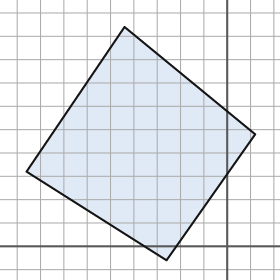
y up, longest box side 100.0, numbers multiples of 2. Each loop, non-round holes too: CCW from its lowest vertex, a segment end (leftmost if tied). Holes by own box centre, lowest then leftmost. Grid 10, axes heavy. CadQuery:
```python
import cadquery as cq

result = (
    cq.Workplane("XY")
    .moveTo(-26.0, -6.0)
    .lineTo(12.0, 48.0)
    .lineTo(-44.0, 94.0)
    .lineTo(-86.0, 32.0)
    .close()
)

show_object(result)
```